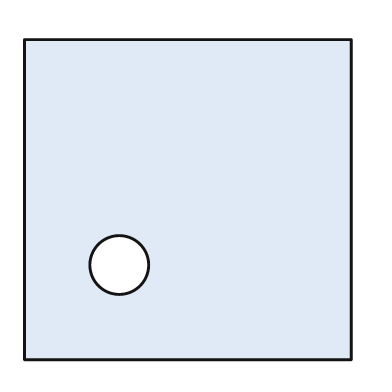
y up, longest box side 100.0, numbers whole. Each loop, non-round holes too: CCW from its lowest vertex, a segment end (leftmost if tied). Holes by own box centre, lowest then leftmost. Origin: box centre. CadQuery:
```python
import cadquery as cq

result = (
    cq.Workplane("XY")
    .moveTo(-50.0, -49.0)
    .lineTo(50.0, -49.0)
    .lineTo(50.0, 49.0)
    .lineTo(-50.0, 49.0)
    .close()
    .moveTo(-21.0, -20.0)
    .circle(9.0)
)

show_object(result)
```